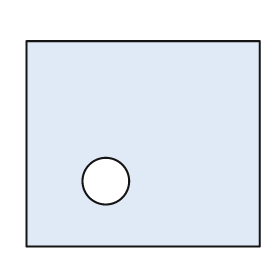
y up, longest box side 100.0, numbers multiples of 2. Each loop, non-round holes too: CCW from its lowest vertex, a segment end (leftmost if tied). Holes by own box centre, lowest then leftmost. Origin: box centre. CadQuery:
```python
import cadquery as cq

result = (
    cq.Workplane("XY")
    .moveTo(-50.0, -44.0)
    .lineTo(50.0, -44.0)
    .lineTo(50.0, 44.0)
    .lineTo(-50.0, 44.0)
    .close()
    .moveTo(-16.0, -16.0)
    .circle(10.0)
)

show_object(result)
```